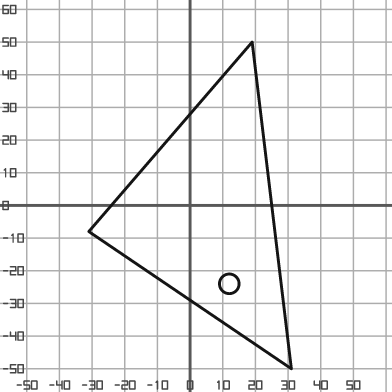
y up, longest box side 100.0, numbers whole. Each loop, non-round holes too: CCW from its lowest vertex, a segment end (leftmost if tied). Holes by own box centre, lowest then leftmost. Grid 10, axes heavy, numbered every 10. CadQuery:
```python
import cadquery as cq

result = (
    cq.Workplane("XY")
    .moveTo(31.0, -50.0)
    .lineTo(19.0, 50.0)
    .lineTo(-31.0, -8.0)
    .close()
    .moveTo(12.0, -24.0)
    .circle(3.0)
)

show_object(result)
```